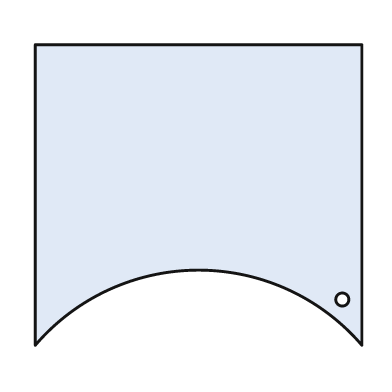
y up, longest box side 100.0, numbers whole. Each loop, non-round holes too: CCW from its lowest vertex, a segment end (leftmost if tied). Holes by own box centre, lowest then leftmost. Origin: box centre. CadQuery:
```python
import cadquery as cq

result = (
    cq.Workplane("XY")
    .moveTo(-50.0, -46.0)
    .threePointArc((0.0, -23.0), (50.0, -46.0))
    .lineTo(50.0, 46.0)
    .lineTo(-50.0, 46.0)
    .close()
    .moveTo(44.0, -32.0)
    .circle(2.0)
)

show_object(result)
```